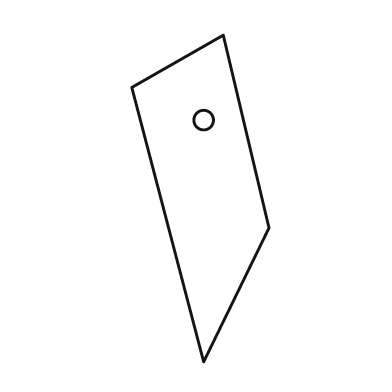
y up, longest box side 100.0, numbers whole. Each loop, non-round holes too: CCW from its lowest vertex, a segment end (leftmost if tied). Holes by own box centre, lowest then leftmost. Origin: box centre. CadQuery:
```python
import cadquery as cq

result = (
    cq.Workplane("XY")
    .moveTo(1.0, -50.0)
    .lineTo(21.0, -9.0)
    .lineTo(7.0, 50.0)
    .lineTo(-21.0, 34.0)
    .close()
    .moveTo(1.0, 24.0)
    .circle(3.0)
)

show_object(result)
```